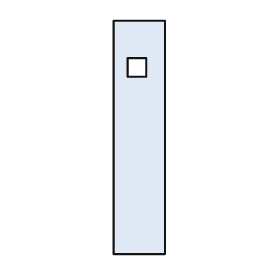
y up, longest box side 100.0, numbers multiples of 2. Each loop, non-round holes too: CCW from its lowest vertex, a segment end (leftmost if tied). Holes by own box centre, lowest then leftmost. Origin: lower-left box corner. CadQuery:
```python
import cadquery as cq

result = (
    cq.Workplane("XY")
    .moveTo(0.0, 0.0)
    .lineTo(22.0, 0.0)
    .lineTo(22.0, 100.0)
    .lineTo(0.0, 100.0)
    .close()
    .moveTo(6.0, 76.0)
    .lineTo(14.0, 76.0)
    .lineTo(14.0, 84.0)
    .lineTo(6.0, 84.0)
    .close()
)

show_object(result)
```